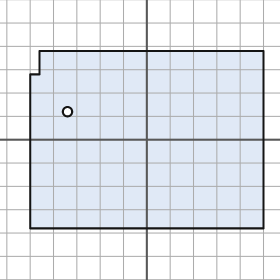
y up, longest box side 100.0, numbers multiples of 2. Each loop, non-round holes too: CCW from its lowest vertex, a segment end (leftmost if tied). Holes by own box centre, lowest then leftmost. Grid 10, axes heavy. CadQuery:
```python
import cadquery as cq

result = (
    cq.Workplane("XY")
    .moveTo(-50.0, -38.0)
    .lineTo(50.0, -38.0)
    .lineTo(50.0, 38.0)
    .lineTo(-46.0, 38.0)
    .lineTo(-46.0, 28.0)
    .lineTo(-50.0, 28.0)
    .close()
    .moveTo(-34.0, 12.0)
    .circle(2.0)
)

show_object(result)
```